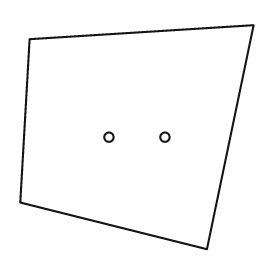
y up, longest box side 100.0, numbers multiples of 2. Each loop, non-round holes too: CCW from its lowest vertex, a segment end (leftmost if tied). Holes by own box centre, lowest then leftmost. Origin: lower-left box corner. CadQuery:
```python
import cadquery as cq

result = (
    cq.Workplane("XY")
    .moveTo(80.0, 0.0)
    .lineTo(100.0, 96.0)
    .lineTo(4.0, 90.0)
    .lineTo(0.0, 20.0)
    .close()
    .moveTo(38.0, 48.0)
    .circle(2.0)
    .moveTo(62.0, 48.0)
    .circle(2.0)
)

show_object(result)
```